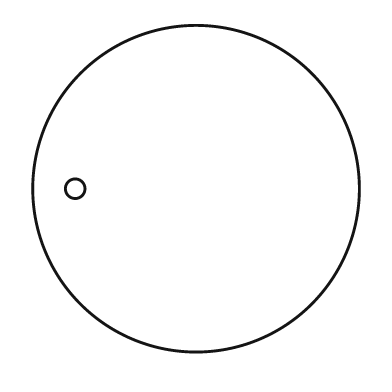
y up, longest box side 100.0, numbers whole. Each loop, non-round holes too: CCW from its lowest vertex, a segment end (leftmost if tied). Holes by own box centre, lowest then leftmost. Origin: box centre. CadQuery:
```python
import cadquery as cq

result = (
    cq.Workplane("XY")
    .moveTo(0.0, 0.0)
    .circle(50.0)
    .moveTo(-37.0, 0.0)
    .circle(3.0)
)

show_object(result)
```